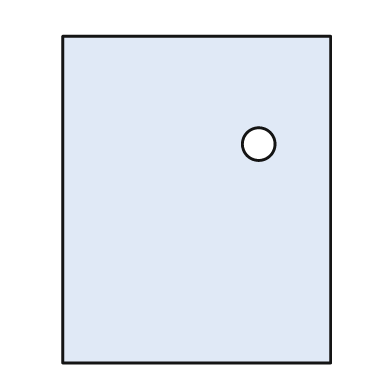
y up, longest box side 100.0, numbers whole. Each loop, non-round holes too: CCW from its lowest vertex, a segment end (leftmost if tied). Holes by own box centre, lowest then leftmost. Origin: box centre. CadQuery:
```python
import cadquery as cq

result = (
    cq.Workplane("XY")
    .moveTo(-41.0, -50.0)
    .lineTo(41.0, -50.0)
    .lineTo(41.0, 50.0)
    .lineTo(-41.0, 50.0)
    .close()
    .moveTo(19.0, 17.0)
    .circle(5.0)
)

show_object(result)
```